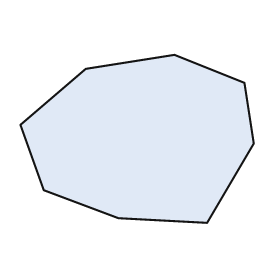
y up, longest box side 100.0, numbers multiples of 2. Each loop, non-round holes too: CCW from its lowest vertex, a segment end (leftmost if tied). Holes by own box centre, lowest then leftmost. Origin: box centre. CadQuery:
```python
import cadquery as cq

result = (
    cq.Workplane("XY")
    .moveTo(30.0, -36.0)
    .lineTo(50.0, -2.0)
    .lineTo(46.0, 24.0)
    .lineTo(16.0, 36.0)
    .lineTo(-22.0, 30.0)
    .lineTo(-50.0, 6.0)
    .lineTo(-40.0, -22.0)
    .lineTo(-8.0, -34.0)
    .close()
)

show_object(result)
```